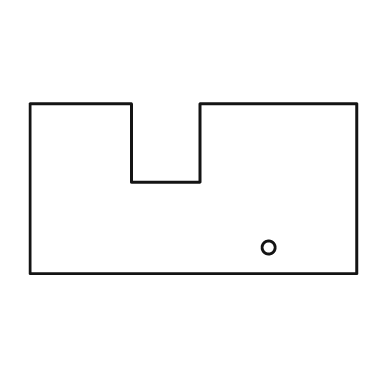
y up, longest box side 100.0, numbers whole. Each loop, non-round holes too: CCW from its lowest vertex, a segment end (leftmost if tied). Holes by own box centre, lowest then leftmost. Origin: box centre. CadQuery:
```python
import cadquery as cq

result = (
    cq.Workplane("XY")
    .moveTo(-50.0, -26.0)
    .lineTo(50.0, -26.0)
    .lineTo(50.0, 26.0)
    .lineTo(2.0, 26.0)
    .lineTo(2.0, 2.0)
    .lineTo(-19.0, 2.0)
    .lineTo(-19.0, 26.0)
    .lineTo(-50.0, 26.0)
    .close()
    .moveTo(23.0, -18.0)
    .circle(2.0)
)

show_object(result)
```